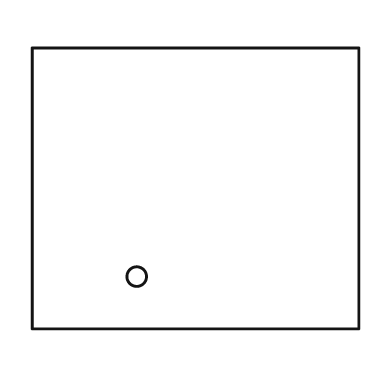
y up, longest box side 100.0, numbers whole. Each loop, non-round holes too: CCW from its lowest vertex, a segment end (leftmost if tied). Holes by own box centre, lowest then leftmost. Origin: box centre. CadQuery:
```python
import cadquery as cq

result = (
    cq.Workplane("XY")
    .moveTo(-50.0, -43.0)
    .lineTo(50.0, -43.0)
    .lineTo(50.0, 43.0)
    .lineTo(-50.0, 43.0)
    .close()
    .moveTo(-18.0, -27.0)
    .circle(3.0)
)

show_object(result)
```